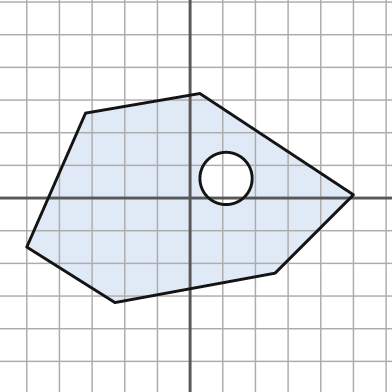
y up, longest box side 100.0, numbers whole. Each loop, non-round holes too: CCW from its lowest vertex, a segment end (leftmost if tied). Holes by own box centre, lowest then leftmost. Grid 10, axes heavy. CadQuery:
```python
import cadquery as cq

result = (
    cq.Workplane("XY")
    .moveTo(-23.0, -32.0)
    .lineTo(26.0, -23.0)
    .lineTo(50.0, 1.0)
    .lineTo(3.0, 32.0)
    .lineTo(-32.0, 26.0)
    .lineTo(-50.0, -15.0)
    .close()
    .moveTo(11.0, 6.0)
    .circle(8.0)
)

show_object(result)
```